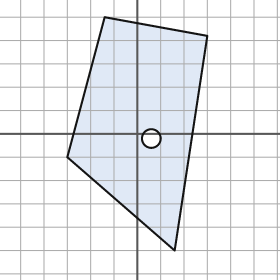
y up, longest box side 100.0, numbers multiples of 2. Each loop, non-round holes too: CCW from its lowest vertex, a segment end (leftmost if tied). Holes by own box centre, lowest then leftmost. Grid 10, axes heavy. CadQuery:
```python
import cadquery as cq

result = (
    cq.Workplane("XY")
    .moveTo(16.0, -50.0)
    .lineTo(30.0, 42.0)
    .lineTo(-14.0, 50.0)
    .lineTo(-30.0, -10.0)
    .close()
    .moveTo(6.0, -2.0)
    .circle(4.0)
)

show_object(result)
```